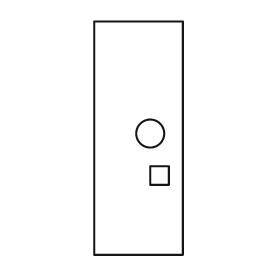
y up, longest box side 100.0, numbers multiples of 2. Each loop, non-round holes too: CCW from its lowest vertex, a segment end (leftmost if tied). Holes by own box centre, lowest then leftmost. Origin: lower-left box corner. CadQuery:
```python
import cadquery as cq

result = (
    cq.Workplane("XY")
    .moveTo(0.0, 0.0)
    .lineTo(38.0, 0.0)
    .lineTo(38.0, 100.0)
    .lineTo(0.0, 100.0)
    .close()
    .moveTo(24.0, 30.0)
    .lineTo(32.0, 30.0)
    .lineTo(32.0, 38.0)
    .lineTo(24.0, 38.0)
    .close()
    .moveTo(24.0, 52.0)
    .circle(6.0)
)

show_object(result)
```